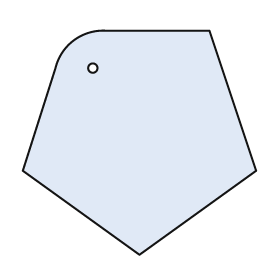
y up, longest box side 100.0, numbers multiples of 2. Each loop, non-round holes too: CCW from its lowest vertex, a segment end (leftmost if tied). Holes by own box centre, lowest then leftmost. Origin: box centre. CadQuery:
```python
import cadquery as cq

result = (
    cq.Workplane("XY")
    .moveTo(0.0, -48.0)
    .lineTo(50.0, -12.0)
    .lineTo(30.0, 48.0)
    .lineTo(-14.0, 48.0)
    .threePointArc((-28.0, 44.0), (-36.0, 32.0))
    .lineTo(-50.0, -12.0)
    .close()
    .moveTo(-20.0, 32.0)
    .circle(2.0)
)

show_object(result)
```